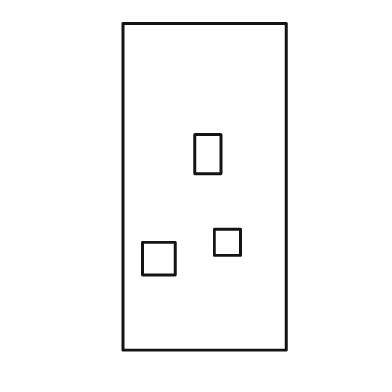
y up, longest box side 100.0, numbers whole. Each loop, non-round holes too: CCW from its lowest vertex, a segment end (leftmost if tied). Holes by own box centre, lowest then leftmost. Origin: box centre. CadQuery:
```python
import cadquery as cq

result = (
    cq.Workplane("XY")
    .moveTo(-25.0, -50.0)
    .lineTo(25.0, -50.0)
    .lineTo(25.0, 50.0)
    .lineTo(-25.0, 50.0)
    .close()
    .moveTo(-19.0, -27.0)
    .lineTo(-9.0, -27.0)
    .lineTo(-9.0, -17.0)
    .lineTo(-19.0, -17.0)
    .close()
    .moveTo(3.0, -21.0)
    .lineTo(11.0, -21.0)
    .lineTo(11.0, -13.0)
    .lineTo(3.0, -13.0)
    .close()
    .moveTo(-3.0, 4.0)
    .lineTo(5.0, 4.0)
    .lineTo(5.0, 16.0)
    .lineTo(-3.0, 16.0)
    .close()
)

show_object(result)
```